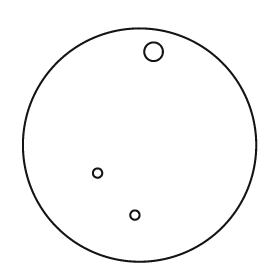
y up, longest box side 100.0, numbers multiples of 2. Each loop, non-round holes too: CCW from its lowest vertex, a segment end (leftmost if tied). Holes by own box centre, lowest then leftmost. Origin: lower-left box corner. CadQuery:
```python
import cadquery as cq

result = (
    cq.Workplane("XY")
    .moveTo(50.0, 50.0)
    .circle(50.0)
    .moveTo(48.0, 20.0)
    .circle(2.0)
    .moveTo(32.0, 38.0)
    .circle(2.0)
    .moveTo(56.0, 90.0)
    .circle(4.0)
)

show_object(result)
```